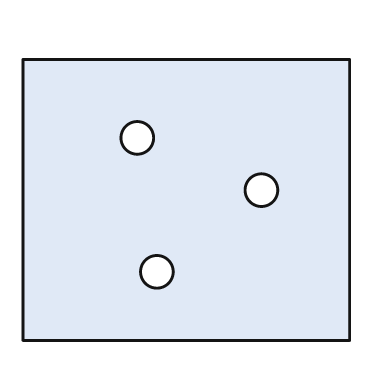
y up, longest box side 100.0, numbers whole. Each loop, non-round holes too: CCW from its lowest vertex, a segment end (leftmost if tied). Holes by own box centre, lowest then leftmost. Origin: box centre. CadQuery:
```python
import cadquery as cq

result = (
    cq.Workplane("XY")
    .moveTo(-50.0, -43.0)
    .lineTo(50.0, -43.0)
    .lineTo(50.0, 43.0)
    .lineTo(-50.0, 43.0)
    .close()
    .moveTo(-9.0, -22.0)
    .circle(5.0)
    .moveTo(23.0, 3.0)
    .circle(5.0)
    .moveTo(-15.0, 19.0)
    .circle(5.0)
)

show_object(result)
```